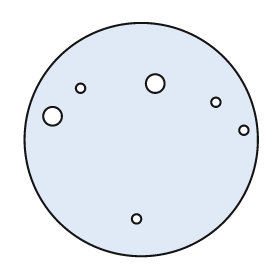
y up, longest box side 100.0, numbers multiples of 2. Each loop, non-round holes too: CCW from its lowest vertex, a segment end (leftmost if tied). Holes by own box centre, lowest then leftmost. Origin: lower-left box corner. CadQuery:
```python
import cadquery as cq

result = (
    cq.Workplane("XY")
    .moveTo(50.0, 50.0)
    .circle(50.0)
    .moveTo(48.0, 16.0)
    .circle(2.0)
    .moveTo(94.0, 54.0)
    .circle(2.0)
    .moveTo(12.0, 60.0)
    .circle(4.0)
    .moveTo(82.0, 66.0)
    .circle(2.0)
    .moveTo(24.0, 72.0)
    .circle(2.0)
    .moveTo(56.0, 74.0)
    .circle(4.0)
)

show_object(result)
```